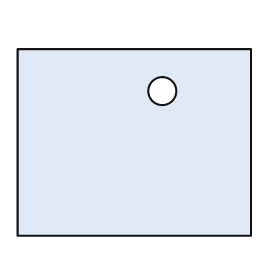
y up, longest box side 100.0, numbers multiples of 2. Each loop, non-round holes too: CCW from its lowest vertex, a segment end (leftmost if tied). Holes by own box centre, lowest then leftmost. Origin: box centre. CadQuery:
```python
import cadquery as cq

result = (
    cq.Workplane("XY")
    .moveTo(-50.0, -40.0)
    .lineTo(50.0, -40.0)
    .lineTo(50.0, 40.0)
    .lineTo(-50.0, 40.0)
    .close()
    .moveTo(12.0, 22.0)
    .circle(6.0)
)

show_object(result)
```